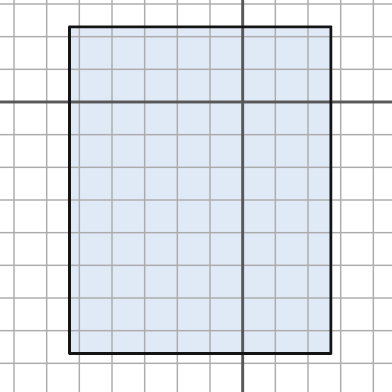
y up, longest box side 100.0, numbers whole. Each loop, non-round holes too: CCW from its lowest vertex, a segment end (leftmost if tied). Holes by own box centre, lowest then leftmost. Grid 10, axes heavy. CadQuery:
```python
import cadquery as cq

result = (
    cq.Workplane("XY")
    .moveTo(-53.0, -77.0)
    .lineTo(27.0, -77.0)
    .lineTo(27.0, 23.0)
    .lineTo(-53.0, 23.0)
    .close()
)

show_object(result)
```